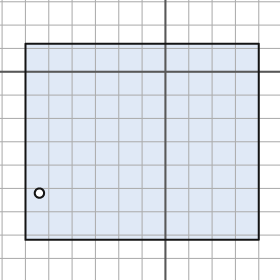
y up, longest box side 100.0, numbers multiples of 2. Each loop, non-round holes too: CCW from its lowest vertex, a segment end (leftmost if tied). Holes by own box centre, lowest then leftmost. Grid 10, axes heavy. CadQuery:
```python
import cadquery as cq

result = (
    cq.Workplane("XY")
    .moveTo(-60.0, -72.0)
    .lineTo(40.0, -72.0)
    .lineTo(40.0, 12.0)
    .lineTo(-60.0, 12.0)
    .close()
    .moveTo(-54.0, -52.0)
    .circle(2.0)
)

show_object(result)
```